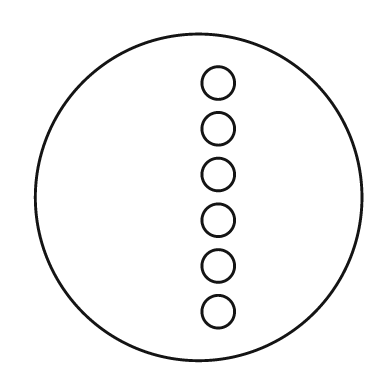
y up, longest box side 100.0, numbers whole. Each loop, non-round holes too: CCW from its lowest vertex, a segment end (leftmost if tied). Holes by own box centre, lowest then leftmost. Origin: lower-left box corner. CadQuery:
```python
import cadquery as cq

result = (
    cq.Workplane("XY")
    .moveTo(50.0, 50.0)
    .circle(50.0)
    .moveTo(56.0, 15.0)
    .circle(5.0)
    .moveTo(56.0, 29.0)
    .circle(5.0)
    .moveTo(56.0, 43.0)
    .circle(5.0)
    .moveTo(56.0, 57.0)
    .circle(5.0)
    .moveTo(56.0, 71.0)
    .circle(5.0)
    .moveTo(56.0, 85.0)
    .circle(5.0)
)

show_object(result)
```